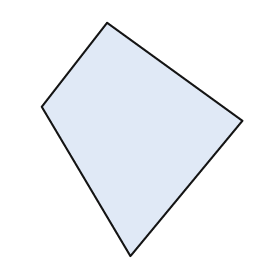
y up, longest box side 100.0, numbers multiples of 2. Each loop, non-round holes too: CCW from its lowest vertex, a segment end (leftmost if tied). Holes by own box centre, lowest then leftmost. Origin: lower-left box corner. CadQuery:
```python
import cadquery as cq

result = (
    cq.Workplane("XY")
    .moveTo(38.0, 0.0)
    .lineTo(86.0, 58.0)
    .lineTo(28.0, 100.0)
    .lineTo(0.0, 64.0)
    .close()
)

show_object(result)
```